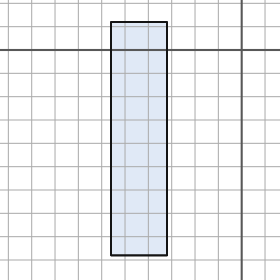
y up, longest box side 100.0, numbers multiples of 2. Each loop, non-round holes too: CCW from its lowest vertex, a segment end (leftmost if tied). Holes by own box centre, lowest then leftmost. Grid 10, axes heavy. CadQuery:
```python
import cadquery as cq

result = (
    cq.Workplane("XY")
    .moveTo(-56.0, -88.0)
    .lineTo(-32.0, -88.0)
    .lineTo(-32.0, 12.0)
    .lineTo(-56.0, 12.0)
    .close()
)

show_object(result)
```